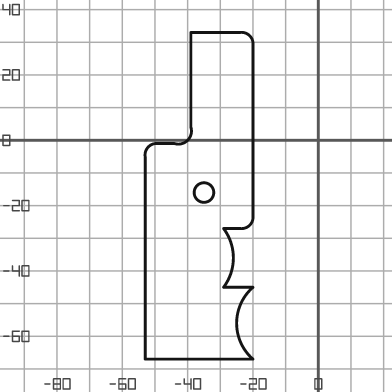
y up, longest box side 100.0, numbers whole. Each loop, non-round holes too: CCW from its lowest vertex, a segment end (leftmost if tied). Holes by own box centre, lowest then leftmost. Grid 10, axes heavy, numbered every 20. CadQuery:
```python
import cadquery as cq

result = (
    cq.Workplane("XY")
    .moveTo(-53.0, -67.0)
    .lineTo(-20.0, -67.0)
    .threePointArc((-25.0, -56.0), (-20.0, -45.0))
    .lineTo(-29.0, -45.0)
    .threePointArc((-26.0, -36.0), (-29.0, -27.0))
    .lineTo(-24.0, -27.0)
    .threePointArc((-21.0, -26.0), (-20.0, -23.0))
    .lineTo(-20.0, 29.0)
    .threePointArc((-21.0, 32.0), (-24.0, 33.0))
    .lineTo(-39.0, 33.0)
    .lineTo(-39.0, 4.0)
    .threePointArc((-40.0, 0.0), (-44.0, -1.0))
    .lineTo(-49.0, -1.0)
    .threePointArc((-52.0, -2.0), (-53.0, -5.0))
    .close()
    .moveTo(-35.0, -16.0)
    .circle(3.0)
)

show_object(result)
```